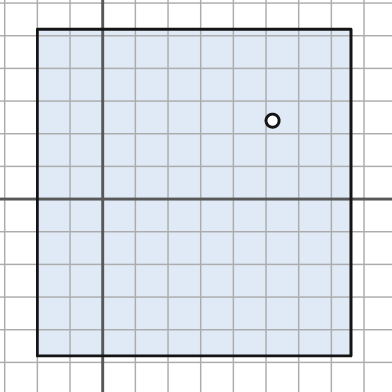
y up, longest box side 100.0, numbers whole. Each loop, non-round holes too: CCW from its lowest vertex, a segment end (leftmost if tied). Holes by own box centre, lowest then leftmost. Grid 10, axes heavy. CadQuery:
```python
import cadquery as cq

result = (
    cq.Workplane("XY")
    .moveTo(-20.0, -48.0)
    .lineTo(76.0, -48.0)
    .lineTo(76.0, 52.0)
    .lineTo(-20.0, 52.0)
    .close()
    .moveTo(52.0, 24.0)
    .circle(2.0)
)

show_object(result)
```